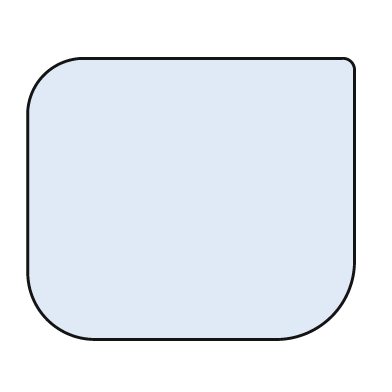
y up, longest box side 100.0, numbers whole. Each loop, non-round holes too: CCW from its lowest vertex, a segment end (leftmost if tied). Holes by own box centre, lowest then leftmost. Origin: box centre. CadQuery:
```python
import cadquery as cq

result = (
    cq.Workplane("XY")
    .moveTo(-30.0, -43.0)
    .lineTo(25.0, -43.0)
    .threePointArc((43.0, -36.0), (50.0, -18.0))
    .lineTo(50.0, 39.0)
    .threePointArc((49.0, 42.0), (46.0, 43.0))
    .lineTo(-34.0, 43.0)
    .threePointArc((-45.0, 38.0), (-50.0, 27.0))
    .lineTo(-50.0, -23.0)
    .threePointArc((-44.0, -37.0), (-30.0, -43.0))
    .close()
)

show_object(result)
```